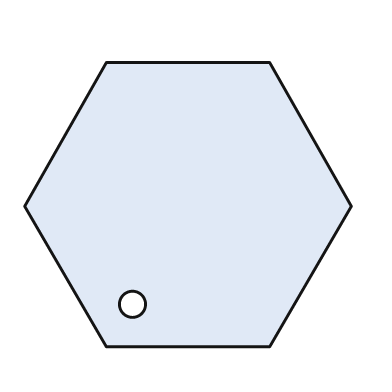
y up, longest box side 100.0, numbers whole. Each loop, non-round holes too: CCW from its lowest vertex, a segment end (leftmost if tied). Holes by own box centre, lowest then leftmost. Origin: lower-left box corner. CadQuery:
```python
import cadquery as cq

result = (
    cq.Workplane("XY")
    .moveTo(25.0, 0.0)
    .lineTo(75.0, 0.0)
    .lineTo(100.0, 43.0)
    .lineTo(75.0, 87.0)
    .lineTo(25.0, 87.0)
    .lineTo(0.0, 43.0)
    .close()
    .moveTo(33.0, 13.0)
    .circle(4.0)
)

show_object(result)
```